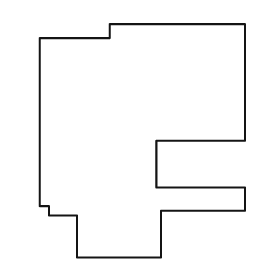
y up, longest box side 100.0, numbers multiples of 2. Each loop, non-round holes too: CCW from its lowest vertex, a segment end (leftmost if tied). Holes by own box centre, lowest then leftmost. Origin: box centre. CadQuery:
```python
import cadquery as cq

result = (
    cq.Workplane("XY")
    .moveTo(-28.0, -50.0)
    .lineTo(8.0, -50.0)
    .lineTo(8.0, -30.0)
    .lineTo(44.0, -30.0)
    .lineTo(44.0, -20.0)
    .lineTo(6.0, -20.0)
    .lineTo(6.0, 0.0)
    .lineTo(44.0, 0.0)
    .lineTo(44.0, 50.0)
    .lineTo(-14.0, 50.0)
    .lineTo(-14.0, 44.0)
    .lineTo(-44.0, 44.0)
    .lineTo(-44.0, -28.0)
    .lineTo(-40.0, -28.0)
    .lineTo(-40.0, -32.0)
    .lineTo(-28.0, -32.0)
    .close()
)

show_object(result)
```